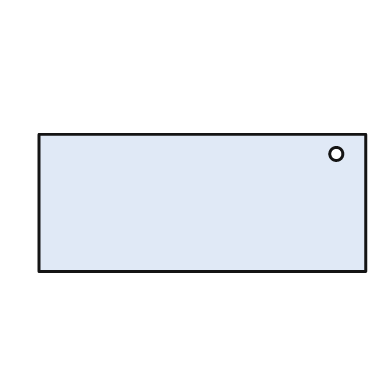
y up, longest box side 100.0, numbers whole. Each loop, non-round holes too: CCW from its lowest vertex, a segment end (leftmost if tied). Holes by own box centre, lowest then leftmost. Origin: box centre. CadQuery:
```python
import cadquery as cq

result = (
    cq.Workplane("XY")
    .moveTo(-50.0, -21.0)
    .lineTo(50.0, -21.0)
    .lineTo(50.0, 21.0)
    .lineTo(-50.0, 21.0)
    .close()
    .moveTo(41.0, 15.0)
    .circle(2.0)
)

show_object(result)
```